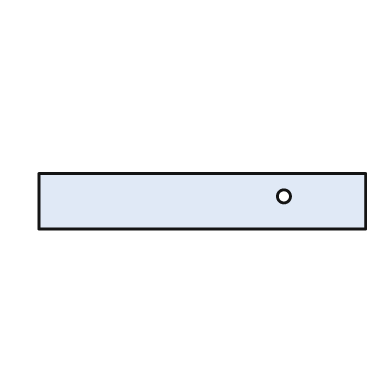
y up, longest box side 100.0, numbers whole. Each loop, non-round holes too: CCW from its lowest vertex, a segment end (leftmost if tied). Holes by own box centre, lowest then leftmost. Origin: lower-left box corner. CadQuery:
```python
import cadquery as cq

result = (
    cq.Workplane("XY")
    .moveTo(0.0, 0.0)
    .lineTo(100.0, 0.0)
    .lineTo(100.0, 17.0)
    .lineTo(0.0, 17.0)
    .close()
    .moveTo(75.0, 10.0)
    .circle(2.0)
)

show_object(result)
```